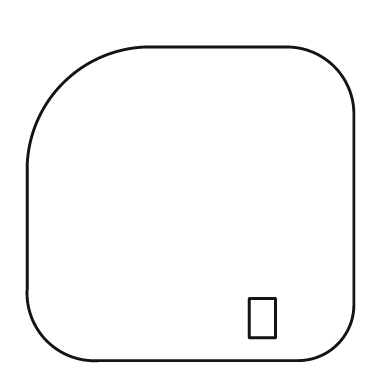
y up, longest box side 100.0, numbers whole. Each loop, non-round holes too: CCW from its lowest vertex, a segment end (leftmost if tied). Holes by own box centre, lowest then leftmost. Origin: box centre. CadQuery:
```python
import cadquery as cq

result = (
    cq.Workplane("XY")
    .moveTo(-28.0, -48.0)
    .lineTo(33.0, -48.0)
    .threePointArc((45.0, -43.0), (50.0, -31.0))
    .lineTo(50.0, 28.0)
    .threePointArc((44.0, 42.0), (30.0, 48.0))
    .lineTo(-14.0, 48.0)
    .threePointArc((-39.0, 37.0), (-50.0, 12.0))
    .lineTo(-50.0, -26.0)
    .threePointArc((-44.0, -42.0), (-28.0, -48.0))
    .close()
    .moveTo(18.0, -41.0)
    .lineTo(26.0, -41.0)
    .lineTo(26.0, -29.0)
    .lineTo(18.0, -29.0)
    .close()
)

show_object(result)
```